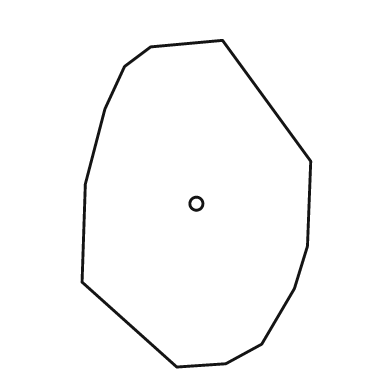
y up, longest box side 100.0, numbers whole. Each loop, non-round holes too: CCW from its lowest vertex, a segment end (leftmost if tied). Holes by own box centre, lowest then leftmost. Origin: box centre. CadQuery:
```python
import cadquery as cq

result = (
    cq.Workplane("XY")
    .moveTo(-6.0, -50.0)
    .lineTo(9.0, -49.0)
    .lineTo(20.0, -43.0)
    .lineTo(30.0, -26.0)
    .lineTo(34.0, -13.0)
    .lineTo(35.0, 13.0)
    .lineTo(8.0, 50.0)
    .lineTo(-14.0, 48.0)
    .lineTo(-22.0, 42.0)
    .lineTo(-28.0, 29.0)
    .lineTo(-34.0, 6.0)
    .lineTo(-35.0, -24.0)
    .close()
    .moveTo(0.0, 0.0)
    .circle(2.0)
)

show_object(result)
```